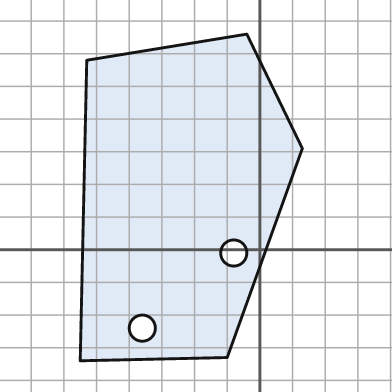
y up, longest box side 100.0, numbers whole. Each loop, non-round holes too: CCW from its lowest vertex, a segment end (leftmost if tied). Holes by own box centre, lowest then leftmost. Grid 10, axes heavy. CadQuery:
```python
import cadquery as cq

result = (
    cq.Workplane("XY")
    .moveTo(-55.0, -34.0)
    .lineTo(-10.0, -33.0)
    .lineTo(13.0, 31.0)
    .lineTo(-4.0, 66.0)
    .lineTo(-53.0, 58.0)
    .close()
    .moveTo(-36.0, -24.0)
    .circle(4.0)
    .moveTo(-8.0, -1.0)
    .circle(4.0)
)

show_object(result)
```